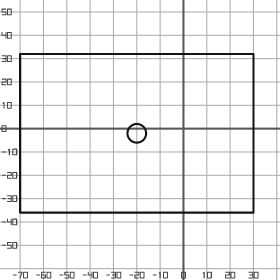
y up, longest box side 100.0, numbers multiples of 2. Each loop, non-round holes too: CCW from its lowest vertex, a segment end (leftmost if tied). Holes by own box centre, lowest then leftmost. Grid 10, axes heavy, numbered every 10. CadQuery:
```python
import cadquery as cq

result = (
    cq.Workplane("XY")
    .moveTo(-70.0, -36.0)
    .lineTo(30.0, -36.0)
    .lineTo(30.0, 32.0)
    .lineTo(-70.0, 32.0)
    .close()
    .moveTo(-20.0, -2.0)
    .circle(4.0)
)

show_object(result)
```